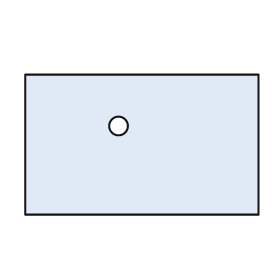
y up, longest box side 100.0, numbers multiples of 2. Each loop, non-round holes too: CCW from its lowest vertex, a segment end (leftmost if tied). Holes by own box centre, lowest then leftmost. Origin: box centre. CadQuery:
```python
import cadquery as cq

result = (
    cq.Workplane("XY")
    .moveTo(-50.0, -30.0)
    .lineTo(50.0, -30.0)
    .lineTo(50.0, 30.0)
    .lineTo(-50.0, 30.0)
    .close()
    .moveTo(-10.0, 8.0)
    .circle(4.0)
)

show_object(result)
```